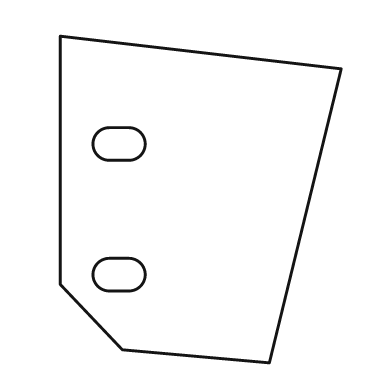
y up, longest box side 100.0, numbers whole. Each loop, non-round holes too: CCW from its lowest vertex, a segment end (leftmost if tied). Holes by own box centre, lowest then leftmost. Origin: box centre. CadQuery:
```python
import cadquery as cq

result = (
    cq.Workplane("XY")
    .moveTo(21.0, -50.0)
    .lineTo(43.0, 40.0)
    .lineTo(-43.0, 50.0)
    .lineTo(-43.0, -26.0)
    .lineTo(-24.0, -46.0)
    .close()
    .moveTo(-28.0, -28.0)
    .lineTo(-22.0, -28.0)
    .threePointArc((-17.0, -23.0), (-22.0, -18.0))
    .lineTo(-28.0, -18.0)
    .threePointArc((-33.0, -23.0), (-28.0, -28.0))
    .close()
    .moveTo(-28.0, 12.0)
    .lineTo(-22.0, 12.0)
    .threePointArc((-17.0, 17.0), (-22.0, 22.0))
    .lineTo(-28.0, 22.0)
    .threePointArc((-33.0, 17.0), (-28.0, 12.0))
    .close()
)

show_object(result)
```